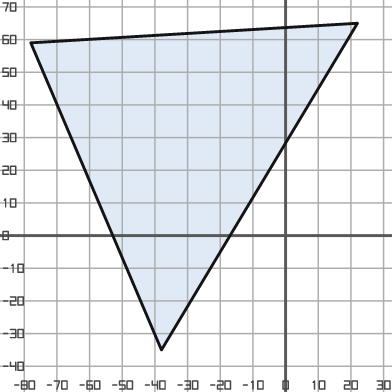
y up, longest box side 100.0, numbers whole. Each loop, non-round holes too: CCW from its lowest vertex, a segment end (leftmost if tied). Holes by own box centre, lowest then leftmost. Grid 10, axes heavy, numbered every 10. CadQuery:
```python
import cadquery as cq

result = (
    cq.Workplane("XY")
    .moveTo(-38.0, -35.0)
    .lineTo(22.0, 65.0)
    .lineTo(-78.0, 59.0)
    .close()
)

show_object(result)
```